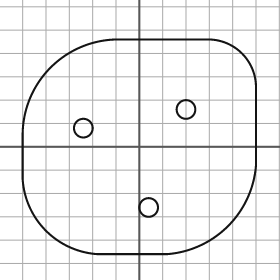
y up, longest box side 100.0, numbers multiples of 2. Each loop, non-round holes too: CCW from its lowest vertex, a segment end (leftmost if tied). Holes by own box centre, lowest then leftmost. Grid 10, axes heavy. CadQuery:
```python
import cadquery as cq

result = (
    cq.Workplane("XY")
    .moveTo(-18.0, -46.0)
    .lineTo(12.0, -46.0)
    .threePointArc((38.0, -34.0), (50.0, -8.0))
    .lineTo(50.0, 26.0)
    .threePointArc((44.0, 40.0), (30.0, 46.0))
    .lineTo(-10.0, 46.0)
    .threePointArc((-38.0, 34.0), (-50.0, 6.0))
    .lineTo(-50.0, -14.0)
    .threePointArc((-40.0, -36.0), (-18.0, -46.0))
    .close()
    .moveTo(4.0, -26.0)
    .circle(4.0)
    .moveTo(-24.0, 8.0)
    .circle(4.0)
    .moveTo(20.0, 16.0)
    .circle(4.0)
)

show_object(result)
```